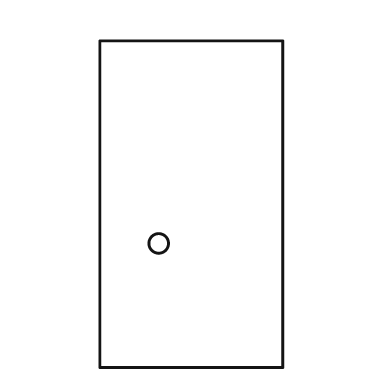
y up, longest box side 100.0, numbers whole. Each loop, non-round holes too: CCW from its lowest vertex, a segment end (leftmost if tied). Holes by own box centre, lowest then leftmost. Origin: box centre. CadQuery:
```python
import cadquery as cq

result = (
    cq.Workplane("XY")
    .moveTo(-28.0, -50.0)
    .lineTo(28.0, -50.0)
    .lineTo(28.0, 50.0)
    .lineTo(-28.0, 50.0)
    .close()
    .moveTo(-10.0, -12.0)
    .circle(3.0)
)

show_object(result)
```